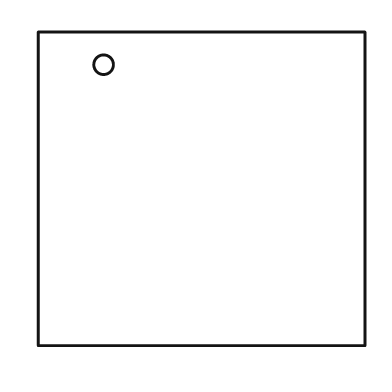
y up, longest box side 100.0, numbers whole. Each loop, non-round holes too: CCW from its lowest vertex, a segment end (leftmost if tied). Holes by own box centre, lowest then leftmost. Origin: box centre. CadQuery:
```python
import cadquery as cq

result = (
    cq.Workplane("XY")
    .moveTo(-50.0, -48.0)
    .lineTo(50.0, -48.0)
    .lineTo(50.0, 48.0)
    .lineTo(-50.0, 48.0)
    .close()
    .moveTo(-30.0, 38.0)
    .circle(3.0)
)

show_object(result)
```